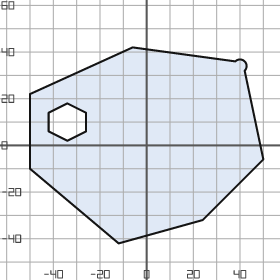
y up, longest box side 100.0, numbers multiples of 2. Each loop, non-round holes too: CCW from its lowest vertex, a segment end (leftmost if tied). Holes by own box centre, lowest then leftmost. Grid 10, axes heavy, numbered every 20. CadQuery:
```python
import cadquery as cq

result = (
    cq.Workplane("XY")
    .moveTo(-12.0, -42.0)
    .lineTo(24.0, -32.0)
    .lineTo(50.0, -6.0)
    .lineTo(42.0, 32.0)
    .threePointArc((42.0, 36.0), (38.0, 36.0))
    .lineTo(-6.0, 42.0)
    .lineTo(-50.0, 22.0)
    .lineTo(-50.0, -10.0)
    .close()
    .moveTo(-34.0, 2.0)
    .lineTo(-26.0, 6.0)
    .lineTo(-26.0, 14.0)
    .lineTo(-34.0, 18.0)
    .lineTo(-42.0, 14.0)
    .lineTo(-42.0, 6.0)
    .close()
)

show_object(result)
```